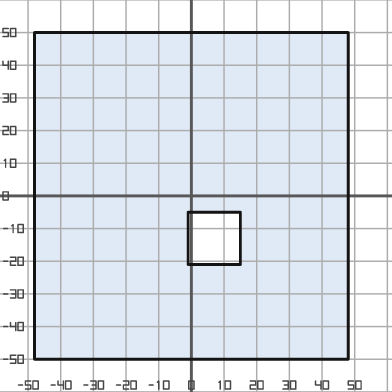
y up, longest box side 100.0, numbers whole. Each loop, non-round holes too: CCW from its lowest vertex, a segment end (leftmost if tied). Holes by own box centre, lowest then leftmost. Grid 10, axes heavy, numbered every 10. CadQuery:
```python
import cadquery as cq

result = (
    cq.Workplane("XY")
    .moveTo(-48.0, -50.0)
    .lineTo(48.0, -50.0)
    .lineTo(48.0, 50.0)
    .lineTo(-48.0, 50.0)
    .close()
    .moveTo(-1.0, -21.0)
    .lineTo(15.0, -21.0)
    .lineTo(15.0, -5.0)
    .lineTo(-1.0, -5.0)
    .close()
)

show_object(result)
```